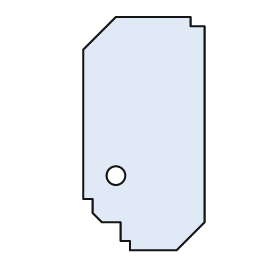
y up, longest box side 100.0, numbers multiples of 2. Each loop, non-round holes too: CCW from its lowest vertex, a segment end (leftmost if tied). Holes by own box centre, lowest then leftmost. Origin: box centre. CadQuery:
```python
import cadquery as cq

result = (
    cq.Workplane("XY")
    .moveTo(-6.0, -50.0)
    .lineTo(14.0, -50.0)
    .lineTo(26.0, -38.0)
    .lineTo(26.0, 46.0)
    .lineTo(20.0, 46.0)
    .lineTo(20.0, 50.0)
    .lineTo(-12.0, 50.0)
    .lineTo(-26.0, 36.0)
    .lineTo(-26.0, -28.0)
    .lineTo(-22.0, -28.0)
    .lineTo(-22.0, -34.0)
    .lineTo(-18.0, -38.0)
    .lineTo(-10.0, -38.0)
    .lineTo(-10.0, -46.0)
    .lineTo(-6.0, -46.0)
    .close()
    .moveTo(-12.0, -18.0)
    .circle(4.0)
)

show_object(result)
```